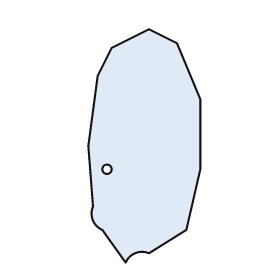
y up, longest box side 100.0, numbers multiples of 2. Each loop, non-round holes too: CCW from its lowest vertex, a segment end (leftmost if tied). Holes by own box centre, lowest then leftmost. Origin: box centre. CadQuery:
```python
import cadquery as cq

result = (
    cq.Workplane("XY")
    .moveTo(-8.0, -50.0)
    .threePointArc((-4.0, -46.0), (2.0, -46.0))
    .lineTo(18.0, -36.0)
    .lineTo(24.0, -10.0)
    .lineTo(24.0, 20.0)
    .lineTo(14.0, 44.0)
    .lineTo(2.0, 50.0)
    .lineTo(-14.0, 42.0)
    .lineTo(-20.0, 30.0)
    .lineTo(-24.0, 0.0)
    .lineTo(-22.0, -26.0)
    .threePointArc((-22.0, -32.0), (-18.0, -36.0))
    .close()
    .moveTo(-16.0, -10.0)
    .circle(2.0)
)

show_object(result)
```